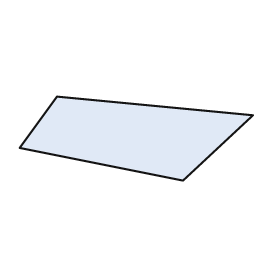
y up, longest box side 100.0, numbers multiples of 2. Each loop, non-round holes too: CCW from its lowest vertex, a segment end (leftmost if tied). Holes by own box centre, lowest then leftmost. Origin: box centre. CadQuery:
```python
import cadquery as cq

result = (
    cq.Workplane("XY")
    .moveTo(20.0, -18.0)
    .lineTo(50.0, 10.0)
    .lineTo(-34.0, 18.0)
    .lineTo(-50.0, -4.0)
    .close()
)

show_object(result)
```